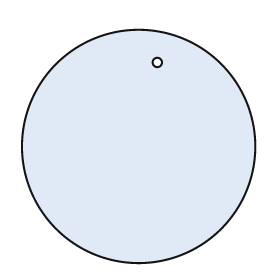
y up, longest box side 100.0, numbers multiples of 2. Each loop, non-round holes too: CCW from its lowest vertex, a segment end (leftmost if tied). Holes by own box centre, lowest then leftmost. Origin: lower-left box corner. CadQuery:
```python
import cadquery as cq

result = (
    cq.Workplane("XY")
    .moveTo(50.0, 50.0)
    .circle(50.0)
    .moveTo(58.0, 86.0)
    .circle(2.0)
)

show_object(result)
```